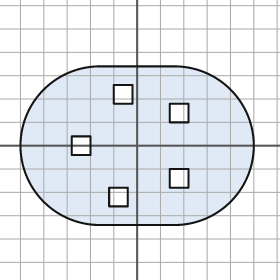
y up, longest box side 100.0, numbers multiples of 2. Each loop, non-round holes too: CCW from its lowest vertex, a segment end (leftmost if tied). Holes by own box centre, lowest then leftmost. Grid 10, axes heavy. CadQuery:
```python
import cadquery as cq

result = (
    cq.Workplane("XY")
    .moveTo(-16.0, -34.0)
    .lineTo(16.0, -34.0)
    .threePointArc((50.0, 0.0), (16.0, 34.0))
    .lineTo(-16.0, 34.0)
    .threePointArc((-50.0, 0.0), (-16.0, -34.0))
    .close()
    .moveTo(-12.0, -26.0)
    .lineTo(-4.0, -26.0)
    .lineTo(-4.0, -18.0)
    .lineTo(-12.0, -18.0)
    .close()
    .moveTo(14.0, -18.0)
    .lineTo(22.0, -18.0)
    .lineTo(22.0, -10.0)
    .lineTo(14.0, -10.0)
    .close()
    .moveTo(-28.0, -4.0)
    .lineTo(-20.0, -4.0)
    .lineTo(-20.0, 4.0)
    .lineTo(-28.0, 4.0)
    .close()
    .moveTo(14.0, 10.0)
    .lineTo(22.0, 10.0)
    .lineTo(22.0, 18.0)
    .lineTo(14.0, 18.0)
    .close()
    .moveTo(-10.0, 18.0)
    .lineTo(-2.0, 18.0)
    .lineTo(-2.0, 26.0)
    .lineTo(-10.0, 26.0)
    .close()
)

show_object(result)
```